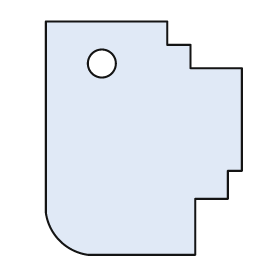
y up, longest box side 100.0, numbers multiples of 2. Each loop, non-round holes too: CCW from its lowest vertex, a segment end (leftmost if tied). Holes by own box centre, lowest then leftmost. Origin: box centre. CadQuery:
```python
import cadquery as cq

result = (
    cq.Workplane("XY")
    .moveTo(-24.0, -50.0)
    .lineTo(22.0, -50.0)
    .lineTo(22.0, -26.0)
    .lineTo(36.0, -26.0)
    .lineTo(36.0, -14.0)
    .lineTo(42.0, -14.0)
    .lineTo(42.0, 30.0)
    .lineTo(20.0, 30.0)
    .lineTo(20.0, 40.0)
    .lineTo(10.0, 40.0)
    .lineTo(10.0, 50.0)
    .lineTo(-42.0, 50.0)
    .lineTo(-42.0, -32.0)
    .threePointArc((-36.0, -44.0), (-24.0, -50.0))
    .close()
    .moveTo(-18.0, 32.0)
    .circle(6.0)
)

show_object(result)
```